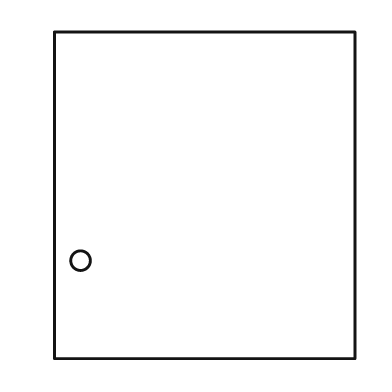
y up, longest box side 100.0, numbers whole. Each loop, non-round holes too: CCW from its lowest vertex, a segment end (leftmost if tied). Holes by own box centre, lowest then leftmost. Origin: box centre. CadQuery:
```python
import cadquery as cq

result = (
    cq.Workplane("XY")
    .moveTo(-46.0, -50.0)
    .lineTo(46.0, -50.0)
    .lineTo(46.0, 50.0)
    .lineTo(-46.0, 50.0)
    .close()
    .moveTo(-38.0, -20.0)
    .circle(3.0)
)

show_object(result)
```